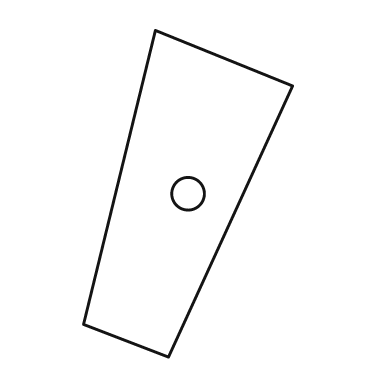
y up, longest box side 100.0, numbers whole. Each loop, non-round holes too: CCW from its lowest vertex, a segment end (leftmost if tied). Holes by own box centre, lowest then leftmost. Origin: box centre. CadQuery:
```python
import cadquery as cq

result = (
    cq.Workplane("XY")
    .moveTo(-6.0, -50.0)
    .lineTo(32.0, 33.0)
    .lineTo(-10.0, 50.0)
    .lineTo(-32.0, -40.0)
    .close()
    .moveTo(0.0, 0.0)
    .circle(5.0)
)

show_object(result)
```